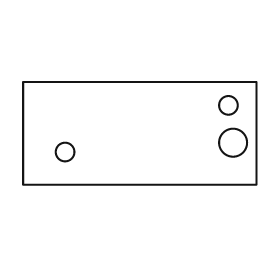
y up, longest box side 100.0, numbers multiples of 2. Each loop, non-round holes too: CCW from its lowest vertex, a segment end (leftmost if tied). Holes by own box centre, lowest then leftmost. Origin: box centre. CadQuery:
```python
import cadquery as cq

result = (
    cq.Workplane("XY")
    .moveTo(-50.0, -22.0)
    .lineTo(50.0, -22.0)
    .lineTo(50.0, 22.0)
    .lineTo(-50.0, 22.0)
    .close()
    .moveTo(-32.0, -8.0)
    .circle(4.0)
    .moveTo(40.0, -4.0)
    .circle(6.0)
    .moveTo(38.0, 12.0)
    .circle(4.0)
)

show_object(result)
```